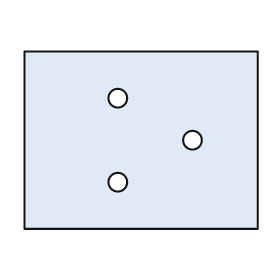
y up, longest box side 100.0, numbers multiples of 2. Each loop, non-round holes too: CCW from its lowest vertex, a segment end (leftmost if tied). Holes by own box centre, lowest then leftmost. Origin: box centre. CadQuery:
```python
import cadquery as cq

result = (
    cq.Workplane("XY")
    .moveTo(-50.0, -38.0)
    .lineTo(50.0, -38.0)
    .lineTo(50.0, 38.0)
    .lineTo(-50.0, 38.0)
    .close()
    .moveTo(-10.0, -18.0)
    .circle(4.0)
    .moveTo(22.0, 0.0)
    .circle(4.0)
    .moveTo(-10.0, 18.0)
    .circle(4.0)
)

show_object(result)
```